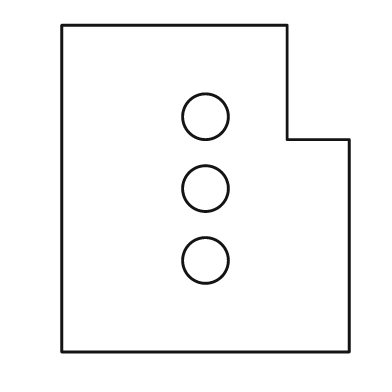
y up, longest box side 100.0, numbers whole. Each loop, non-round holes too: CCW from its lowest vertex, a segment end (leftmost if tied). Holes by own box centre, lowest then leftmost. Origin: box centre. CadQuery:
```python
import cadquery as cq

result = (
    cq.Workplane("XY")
    .moveTo(-44.0, -50.0)
    .lineTo(44.0, -50.0)
    .lineTo(44.0, 15.0)
    .lineTo(25.0, 15.0)
    .lineTo(25.0, 50.0)
    .lineTo(-44.0, 50.0)
    .close()
    .moveTo(0.0, -22.0)
    .circle(7.0)
    .moveTo(0.0, 0.0)
    .circle(7.0)
    .moveTo(0.0, 22.0)
    .circle(7.0)
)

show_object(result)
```